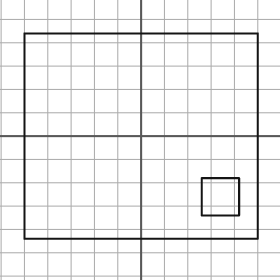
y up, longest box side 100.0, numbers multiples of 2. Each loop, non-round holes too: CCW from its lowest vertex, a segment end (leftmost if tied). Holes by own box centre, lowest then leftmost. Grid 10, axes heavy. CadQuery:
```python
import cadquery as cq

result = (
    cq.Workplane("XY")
    .moveTo(-50.0, -44.0)
    .lineTo(50.0, -44.0)
    .lineTo(50.0, 44.0)
    .lineTo(-50.0, 44.0)
    .close()
    .moveTo(26.0, -34.0)
    .lineTo(42.0, -34.0)
    .lineTo(42.0, -18.0)
    .lineTo(26.0, -18.0)
    .close()
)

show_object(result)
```